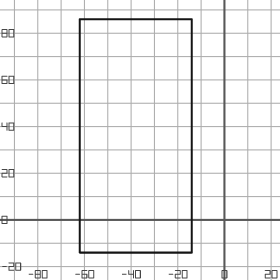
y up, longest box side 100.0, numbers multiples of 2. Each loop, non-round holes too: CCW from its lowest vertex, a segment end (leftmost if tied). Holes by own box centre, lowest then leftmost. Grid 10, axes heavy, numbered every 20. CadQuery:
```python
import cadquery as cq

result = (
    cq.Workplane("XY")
    .moveTo(-62.0, -14.0)
    .lineTo(-14.0, -14.0)
    .lineTo(-14.0, 86.0)
    .lineTo(-62.0, 86.0)
    .close()
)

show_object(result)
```